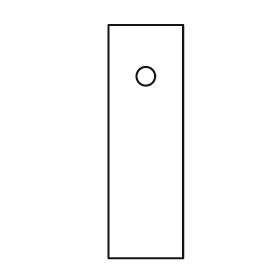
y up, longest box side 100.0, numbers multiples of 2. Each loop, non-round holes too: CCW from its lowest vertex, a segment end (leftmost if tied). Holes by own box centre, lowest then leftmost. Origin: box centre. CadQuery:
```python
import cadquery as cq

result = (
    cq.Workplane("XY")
    .moveTo(-16.0, -50.0)
    .lineTo(16.0, -50.0)
    .lineTo(16.0, 50.0)
    .lineTo(-16.0, 50.0)
    .close()
    .moveTo(0.0, 28.0)
    .circle(4.0)
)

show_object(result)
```